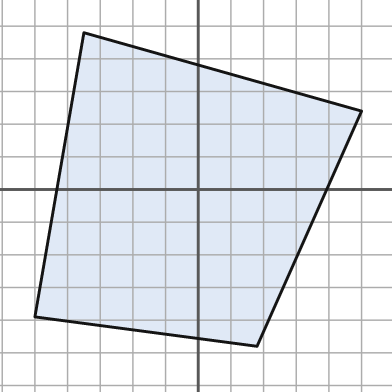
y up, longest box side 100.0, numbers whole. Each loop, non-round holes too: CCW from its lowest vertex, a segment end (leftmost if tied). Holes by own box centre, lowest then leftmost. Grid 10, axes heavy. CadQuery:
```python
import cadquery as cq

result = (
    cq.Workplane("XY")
    .moveTo(18.0, -48.0)
    .lineTo(50.0, 24.0)
    .lineTo(-35.0, 48.0)
    .lineTo(-50.0, -39.0)
    .close()
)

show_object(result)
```